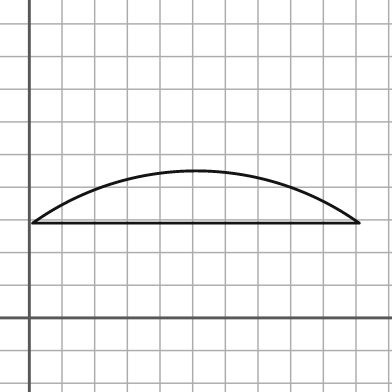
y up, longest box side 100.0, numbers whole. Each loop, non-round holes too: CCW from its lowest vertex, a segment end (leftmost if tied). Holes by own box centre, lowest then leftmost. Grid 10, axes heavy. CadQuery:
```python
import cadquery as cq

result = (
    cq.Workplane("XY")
    .moveTo(1.0, 29.0)
    .lineTo(101.0, 29.0)
    .threePointArc((51.0, 45.0), (1.0, 29.0))
    .close()
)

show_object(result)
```